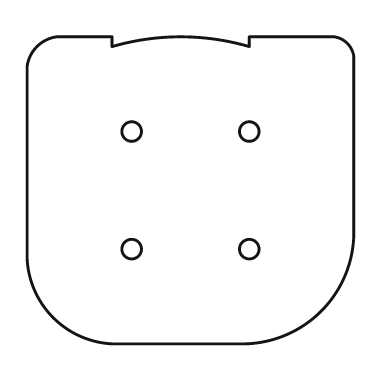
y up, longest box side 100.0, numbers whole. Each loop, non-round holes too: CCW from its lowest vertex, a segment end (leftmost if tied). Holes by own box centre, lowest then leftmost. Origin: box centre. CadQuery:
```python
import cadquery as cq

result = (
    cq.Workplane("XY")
    .moveTo(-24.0, -47.0)
    .lineTo(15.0, -47.0)
    .threePointArc((40.0, -37.0), (50.0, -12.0))
    .lineTo(50.0, 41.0)
    .threePointArc((48.0, 45.0), (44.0, 47.0))
    .lineTo(18.0, 47.0)
    .lineTo(18.0, 44.0)
    .threePointArc((-3.0, 47.0), (-24.0, 44.0))
    .lineTo(-24.0, 47.0)
    .lineTo(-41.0, 47.0)
    .threePointArc((-47.0, 44.0), (-50.0, 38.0))
    .lineTo(-50.0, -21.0)
    .threePointArc((-42.0, -39.0), (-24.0, -47.0))
    .close()
    .moveTo(-18.0, -18.0)
    .circle(3.0)
    .moveTo(18.0, -18.0)
    .circle(3.0)
    .moveTo(-18.0, 18.0)
    .circle(3.0)
    .moveTo(18.0, 18.0)
    .circle(3.0)
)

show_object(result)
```